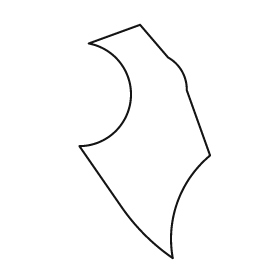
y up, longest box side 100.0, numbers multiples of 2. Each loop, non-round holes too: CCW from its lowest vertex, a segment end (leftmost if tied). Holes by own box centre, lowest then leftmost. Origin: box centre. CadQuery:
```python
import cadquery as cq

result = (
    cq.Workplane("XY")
    .moveTo(12.0, -50.0)
    .threePointArc((14.0, -26.0), (28.0, -6.0))
    .lineTo(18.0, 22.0)
    .threePointArc((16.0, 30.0), (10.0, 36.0))
    .lineTo(-2.0, 50.0)
    .lineTo(-24.0, 42.0)
    .threePointArc((-6.0, 18.0), (-28.0, -2.0))
    .lineTo(-10.0, -28.0)
    .threePointArc((0.0, -40.0), (12.0, -50.0))
    .close()
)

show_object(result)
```